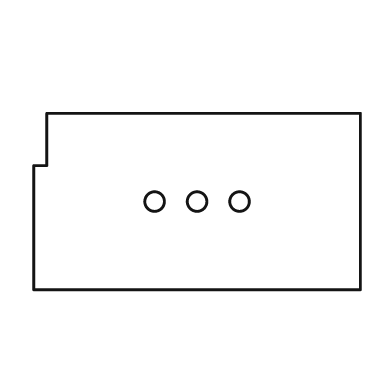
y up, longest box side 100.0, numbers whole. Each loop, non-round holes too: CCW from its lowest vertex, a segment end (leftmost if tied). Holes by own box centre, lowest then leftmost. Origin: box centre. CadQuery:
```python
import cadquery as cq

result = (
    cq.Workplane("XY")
    .moveTo(-50.0, -27.0)
    .lineTo(50.0, -27.0)
    .lineTo(50.0, 27.0)
    .lineTo(-46.0, 27.0)
    .lineTo(-46.0, 11.0)
    .lineTo(-50.0, 11.0)
    .close()
    .moveTo(-13.0, 0.0)
    .circle(3.0)
    .moveTo(0.0, 0.0)
    .circle(3.0)
    .moveTo(13.0, 0.0)
    .circle(3.0)
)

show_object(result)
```